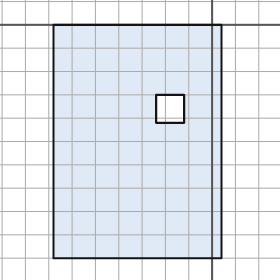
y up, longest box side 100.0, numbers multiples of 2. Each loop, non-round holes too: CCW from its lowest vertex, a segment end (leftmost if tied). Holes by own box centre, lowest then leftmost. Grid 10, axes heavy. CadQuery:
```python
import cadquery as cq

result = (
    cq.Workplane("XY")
    .moveTo(-68.0, -100.0)
    .lineTo(4.0, -100.0)
    .lineTo(4.0, 0.0)
    .lineTo(-68.0, 0.0)
    .close()
    .moveTo(-24.0, -42.0)
    .lineTo(-12.0, -42.0)
    .lineTo(-12.0, -30.0)
    .lineTo(-24.0, -30.0)
    .close()
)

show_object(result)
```